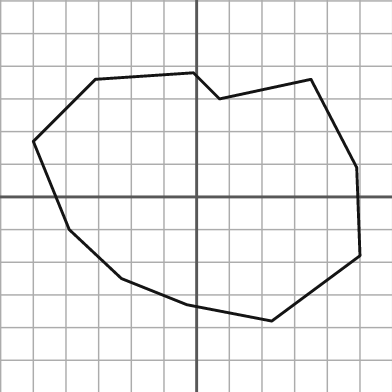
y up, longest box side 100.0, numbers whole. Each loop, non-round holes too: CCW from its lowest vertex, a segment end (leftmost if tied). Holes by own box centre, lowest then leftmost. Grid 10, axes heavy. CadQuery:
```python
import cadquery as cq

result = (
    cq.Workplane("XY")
    .moveTo(23.0, -38.0)
    .lineTo(50.0, -18.0)
    .lineTo(49.0, 9.0)
    .lineTo(35.0, 36.0)
    .lineTo(7.0, 30.0)
    .lineTo(-1.0, 38.0)
    .lineTo(-31.0, 36.0)
    .lineTo(-50.0, 17.0)
    .lineTo(-39.0, -10.0)
    .lineTo(-23.0, -25.0)
    .lineTo(-3.0, -33.0)
    .close()
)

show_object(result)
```